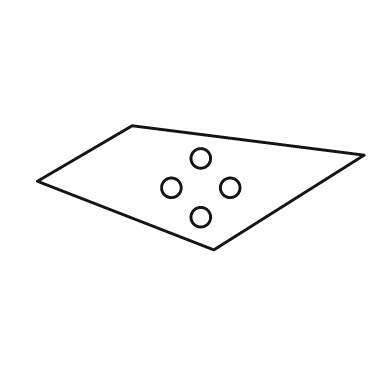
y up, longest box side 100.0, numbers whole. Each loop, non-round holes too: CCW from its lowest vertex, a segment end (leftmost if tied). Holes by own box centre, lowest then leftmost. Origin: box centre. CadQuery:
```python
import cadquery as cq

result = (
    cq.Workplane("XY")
    .moveTo(4.0, -19.0)
    .lineTo(50.0, 10.0)
    .lineTo(-21.0, 19.0)
    .lineTo(-50.0, 2.0)
    .close()
    .moveTo(0.0, -9.0)
    .circle(3.0)
    .moveTo(-9.0, 0.0)
    .circle(3.0)
    .moveTo(9.0, 0.0)
    .circle(3.0)
    .moveTo(0.0, 9.0)
    .circle(3.0)
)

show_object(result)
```